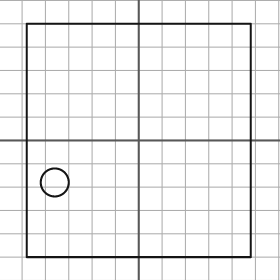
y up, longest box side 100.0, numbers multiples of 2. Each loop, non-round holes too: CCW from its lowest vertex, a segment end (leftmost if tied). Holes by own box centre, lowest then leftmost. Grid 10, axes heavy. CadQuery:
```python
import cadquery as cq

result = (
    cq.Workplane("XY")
    .moveTo(-48.0, -50.0)
    .lineTo(48.0, -50.0)
    .lineTo(48.0, 50.0)
    .lineTo(-48.0, 50.0)
    .close()
    .moveTo(-36.0, -18.0)
    .circle(6.0)
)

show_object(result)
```